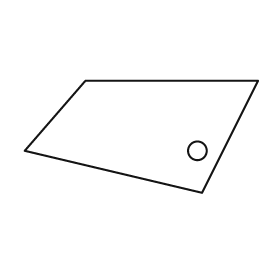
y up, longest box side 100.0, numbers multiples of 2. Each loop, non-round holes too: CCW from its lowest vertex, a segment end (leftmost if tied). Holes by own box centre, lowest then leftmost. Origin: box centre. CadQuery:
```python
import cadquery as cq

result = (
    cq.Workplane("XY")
    .moveTo(26.0, -24.0)
    .lineTo(50.0, 24.0)
    .lineTo(-24.0, 24.0)
    .lineTo(-50.0, -6.0)
    .close()
    .moveTo(24.0, -6.0)
    .circle(4.0)
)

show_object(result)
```